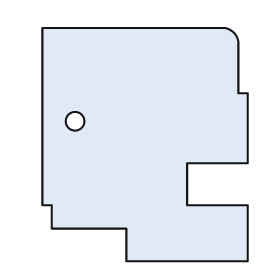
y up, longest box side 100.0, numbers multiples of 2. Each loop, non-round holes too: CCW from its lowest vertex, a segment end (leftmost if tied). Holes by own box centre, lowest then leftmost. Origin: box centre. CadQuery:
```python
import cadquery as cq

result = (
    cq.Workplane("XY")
    .moveTo(-8.0, -50.0)
    .lineTo(44.0, -50.0)
    .lineTo(44.0, -26.0)
    .lineTo(18.0, -26.0)
    .lineTo(18.0, -8.0)
    .lineTo(44.0, -8.0)
    .lineTo(44.0, 22.0)
    .lineTo(40.0, 22.0)
    .lineTo(40.0, 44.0)
    .threePointArc((38.0, 48.0), (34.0, 50.0))
    .lineTo(-44.0, 50.0)
    .lineTo(-44.0, -26.0)
    .lineTo(-40.0, -26.0)
    .lineTo(-40.0, -36.0)
    .lineTo(-8.0, -36.0)
    .close()
    .moveTo(-30.0, 10.0)
    .circle(4.0)
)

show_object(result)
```